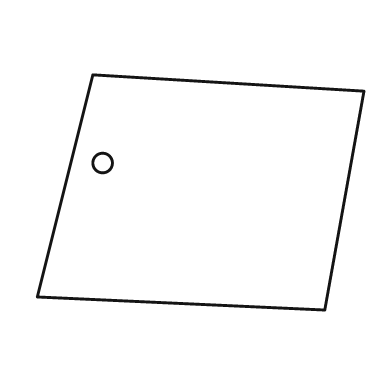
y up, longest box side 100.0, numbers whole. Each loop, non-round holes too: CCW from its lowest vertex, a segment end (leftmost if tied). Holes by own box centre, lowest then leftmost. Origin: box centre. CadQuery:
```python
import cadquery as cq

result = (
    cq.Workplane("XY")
    .moveTo(38.0, -36.0)
    .lineTo(50.0, 31.0)
    .lineTo(-33.0, 36.0)
    .lineTo(-50.0, -32.0)
    .close()
    .moveTo(-30.0, 9.0)
    .circle(3.0)
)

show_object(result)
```